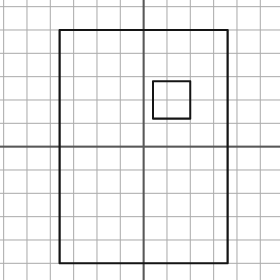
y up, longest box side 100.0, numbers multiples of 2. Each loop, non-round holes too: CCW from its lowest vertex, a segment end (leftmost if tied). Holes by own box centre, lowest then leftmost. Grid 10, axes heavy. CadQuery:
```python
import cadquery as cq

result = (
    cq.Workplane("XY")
    .moveTo(-36.0, -50.0)
    .lineTo(36.0, -50.0)
    .lineTo(36.0, 50.0)
    .lineTo(-36.0, 50.0)
    .close()
    .moveTo(4.0, 12.0)
    .lineTo(20.0, 12.0)
    .lineTo(20.0, 28.0)
    .lineTo(4.0, 28.0)
    .close()
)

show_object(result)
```